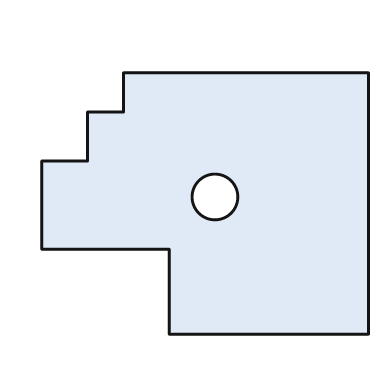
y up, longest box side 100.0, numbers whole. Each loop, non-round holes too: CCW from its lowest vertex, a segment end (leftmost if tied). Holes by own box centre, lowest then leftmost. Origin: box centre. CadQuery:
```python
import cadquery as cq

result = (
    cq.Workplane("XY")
    .moveTo(-11.0, -40.0)
    .lineTo(50.0, -40.0)
    .lineTo(50.0, 40.0)
    .lineTo(-25.0, 40.0)
    .lineTo(-25.0, 28.0)
    .lineTo(-36.0, 28.0)
    .lineTo(-36.0, 13.0)
    .lineTo(-50.0, 13.0)
    .lineTo(-50.0, -14.0)
    .lineTo(-11.0, -14.0)
    .close()
    .moveTo(3.0, 2.0)
    .circle(7.0)
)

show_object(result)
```